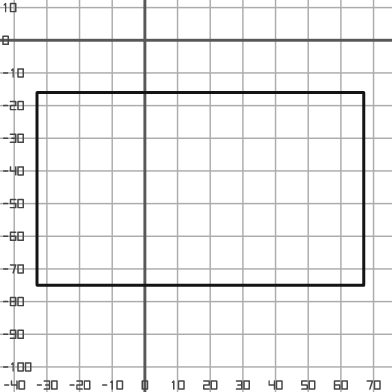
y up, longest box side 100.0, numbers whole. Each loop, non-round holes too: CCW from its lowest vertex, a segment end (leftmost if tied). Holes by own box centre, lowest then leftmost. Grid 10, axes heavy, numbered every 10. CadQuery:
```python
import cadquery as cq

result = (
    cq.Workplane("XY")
    .moveTo(-33.0, -75.0)
    .lineTo(67.0, -75.0)
    .lineTo(67.0, -16.0)
    .lineTo(-33.0, -16.0)
    .close()
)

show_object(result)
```